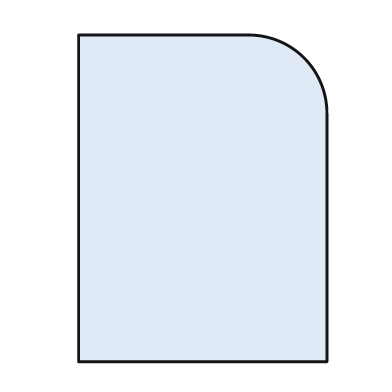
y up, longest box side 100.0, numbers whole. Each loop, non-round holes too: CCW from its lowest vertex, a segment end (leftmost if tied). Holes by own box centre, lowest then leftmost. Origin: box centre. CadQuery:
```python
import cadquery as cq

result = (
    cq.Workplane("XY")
    .moveTo(-38.0, -50.0)
    .lineTo(38.0, -50.0)
    .lineTo(38.0, 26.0)
    .threePointArc((31.0, 43.0), (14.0, 50.0))
    .lineTo(-38.0, 50.0)
    .close()
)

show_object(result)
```